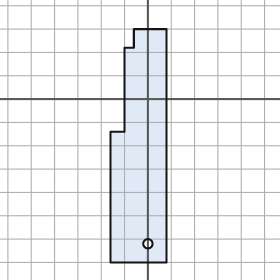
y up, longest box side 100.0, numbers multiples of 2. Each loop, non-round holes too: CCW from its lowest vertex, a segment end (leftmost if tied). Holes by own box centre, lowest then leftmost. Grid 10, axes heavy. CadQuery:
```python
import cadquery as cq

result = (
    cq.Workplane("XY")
    .moveTo(-16.0, -70.0)
    .lineTo(8.0, -70.0)
    .lineTo(8.0, 30.0)
    .lineTo(-6.0, 30.0)
    .lineTo(-6.0, 22.0)
    .lineTo(-10.0, 22.0)
    .lineTo(-10.0, -14.0)
    .lineTo(-16.0, -14.0)
    .close()
    .moveTo(0.0, -62.0)
    .circle(2.0)
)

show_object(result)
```